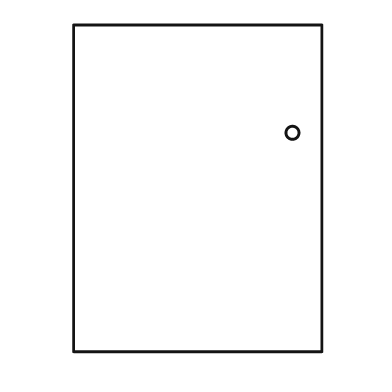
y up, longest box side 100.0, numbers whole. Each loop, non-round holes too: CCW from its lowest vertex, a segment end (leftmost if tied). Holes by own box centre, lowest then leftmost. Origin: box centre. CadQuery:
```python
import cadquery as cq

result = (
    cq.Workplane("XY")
    .moveTo(-38.0, -50.0)
    .lineTo(38.0, -50.0)
    .lineTo(38.0, 50.0)
    .lineTo(-38.0, 50.0)
    .close()
    .moveTo(29.0, 17.0)
    .circle(2.0)
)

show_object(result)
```